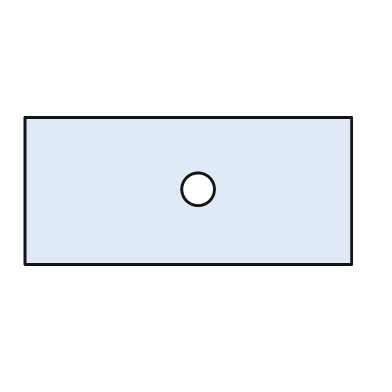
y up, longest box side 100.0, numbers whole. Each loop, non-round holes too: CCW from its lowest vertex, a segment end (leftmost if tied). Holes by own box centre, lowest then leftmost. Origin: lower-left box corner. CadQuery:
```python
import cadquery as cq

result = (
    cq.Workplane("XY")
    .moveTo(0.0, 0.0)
    .lineTo(100.0, 0.0)
    .lineTo(100.0, 45.0)
    .lineTo(0.0, 45.0)
    .close()
    .moveTo(53.0, 23.0)
    .circle(5.0)
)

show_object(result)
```